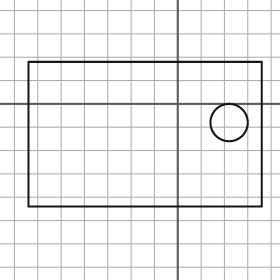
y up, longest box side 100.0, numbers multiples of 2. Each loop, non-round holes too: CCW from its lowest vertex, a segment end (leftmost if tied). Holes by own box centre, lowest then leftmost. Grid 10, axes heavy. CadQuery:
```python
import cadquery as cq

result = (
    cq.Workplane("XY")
    .moveTo(-64.0, -44.0)
    .lineTo(36.0, -44.0)
    .lineTo(36.0, 18.0)
    .lineTo(-64.0, 18.0)
    .close()
    .moveTo(22.0, -8.0)
    .circle(8.0)
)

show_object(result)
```